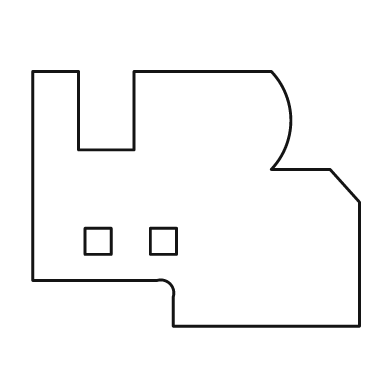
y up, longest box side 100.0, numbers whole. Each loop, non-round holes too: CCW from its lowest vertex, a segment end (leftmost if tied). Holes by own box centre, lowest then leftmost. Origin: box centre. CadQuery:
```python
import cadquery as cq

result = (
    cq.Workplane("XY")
    .moveTo(-7.0, -39.0)
    .lineTo(50.0, -39.0)
    .lineTo(50.0, -1.0)
    .lineTo(41.0, 9.0)
    .lineTo(23.0, 9.0)
    .threePointArc((29.0, 24.0), (23.0, 39.0))
    .lineTo(-19.0, 39.0)
    .lineTo(-19.0, 15.0)
    .lineTo(-36.0, 15.0)
    .lineTo(-36.0, 39.0)
    .lineTo(-50.0, 39.0)
    .lineTo(-50.0, -25.0)
    .lineTo(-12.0, -25.0)
    .threePointArc((-8.0, -26.0), (-7.0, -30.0))
    .close()
    .moveTo(-34.0, -17.0)
    .lineTo(-26.0, -17.0)
    .lineTo(-26.0, -9.0)
    .lineTo(-34.0, -9.0)
    .close()
    .moveTo(-14.0, -17.0)
    .lineTo(-6.0, -17.0)
    .lineTo(-6.0, -9.0)
    .lineTo(-14.0, -9.0)
    .close()
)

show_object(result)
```